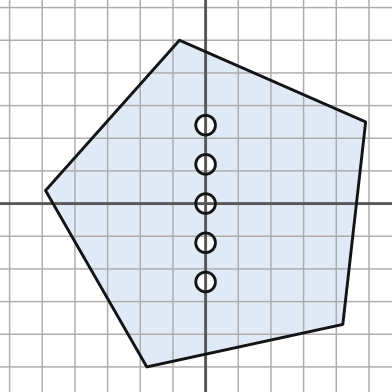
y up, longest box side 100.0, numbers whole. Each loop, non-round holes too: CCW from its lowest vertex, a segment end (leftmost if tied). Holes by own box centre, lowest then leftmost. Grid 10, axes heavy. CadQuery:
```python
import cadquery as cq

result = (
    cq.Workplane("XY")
    .moveTo(-18.0, -50.0)
    .lineTo(42.0, -37.0)
    .lineTo(49.0, 25.0)
    .lineTo(-8.0, 50.0)
    .lineTo(-49.0, 4.0)
    .close()
    .moveTo(0.0, -24.0)
    .circle(3.0)
    .moveTo(0.0, -12.0)
    .circle(3.0)
    .moveTo(0.0, 0.0)
    .circle(3.0)
    .moveTo(0.0, 12.0)
    .circle(3.0)
    .moveTo(0.0, 24.0)
    .circle(3.0)
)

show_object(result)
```